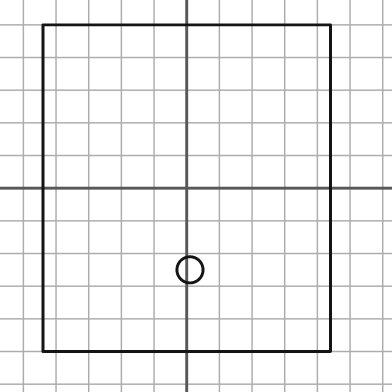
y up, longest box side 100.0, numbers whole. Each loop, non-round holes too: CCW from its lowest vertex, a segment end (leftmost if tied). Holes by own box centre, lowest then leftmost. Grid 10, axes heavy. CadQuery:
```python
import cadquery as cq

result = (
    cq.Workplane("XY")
    .moveTo(-44.0, -50.0)
    .lineTo(44.0, -50.0)
    .lineTo(44.0, 50.0)
    .lineTo(-44.0, 50.0)
    .close()
    .moveTo(1.0, -25.0)
    .circle(4.0)
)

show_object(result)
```